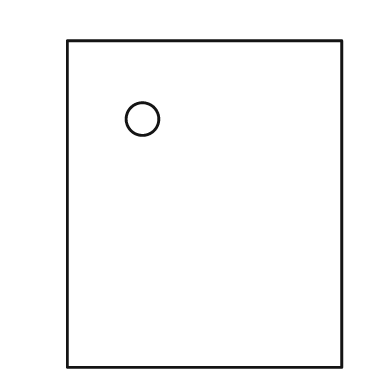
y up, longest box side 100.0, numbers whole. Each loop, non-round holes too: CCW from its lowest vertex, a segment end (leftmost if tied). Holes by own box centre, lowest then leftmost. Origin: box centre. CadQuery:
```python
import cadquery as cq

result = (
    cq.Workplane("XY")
    .moveTo(-42.0, -50.0)
    .lineTo(42.0, -50.0)
    .lineTo(42.0, 50.0)
    .lineTo(-42.0, 50.0)
    .close()
    .moveTo(-19.0, 26.0)
    .circle(5.0)
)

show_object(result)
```